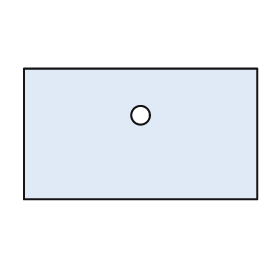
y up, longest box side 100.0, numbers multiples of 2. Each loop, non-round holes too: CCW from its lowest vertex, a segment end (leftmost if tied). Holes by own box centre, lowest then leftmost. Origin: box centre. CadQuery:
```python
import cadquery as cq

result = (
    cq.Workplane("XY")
    .moveTo(-50.0, -28.0)
    .lineTo(50.0, -28.0)
    .lineTo(50.0, 28.0)
    .lineTo(-50.0, 28.0)
    .close()
    .moveTo(0.0, 8.0)
    .circle(4.0)
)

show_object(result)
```